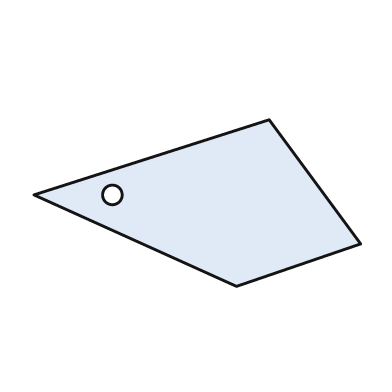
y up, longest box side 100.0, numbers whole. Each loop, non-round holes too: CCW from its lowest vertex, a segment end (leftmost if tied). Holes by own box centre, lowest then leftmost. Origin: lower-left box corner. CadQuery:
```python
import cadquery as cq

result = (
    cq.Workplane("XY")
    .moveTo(62.0, 0.0)
    .lineTo(100.0, 13.0)
    .lineTo(72.0, 51.0)
    .lineTo(0.0, 28.0)
    .close()
    .moveTo(24.0, 28.0)
    .circle(3.0)
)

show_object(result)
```